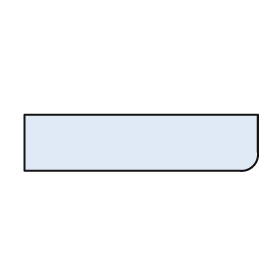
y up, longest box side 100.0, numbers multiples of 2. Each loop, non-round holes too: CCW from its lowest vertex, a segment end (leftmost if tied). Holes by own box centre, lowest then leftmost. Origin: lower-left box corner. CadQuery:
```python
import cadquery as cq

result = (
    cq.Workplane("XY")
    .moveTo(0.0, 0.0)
    .lineTo(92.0, 0.0)
    .threePointArc((98.0, 2.0), (100.0, 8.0))
    .lineTo(100.0, 24.0)
    .lineTo(0.0, 24.0)
    .close()
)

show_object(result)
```